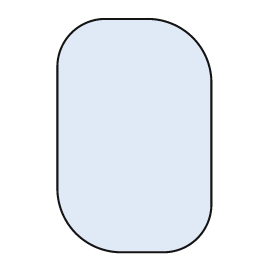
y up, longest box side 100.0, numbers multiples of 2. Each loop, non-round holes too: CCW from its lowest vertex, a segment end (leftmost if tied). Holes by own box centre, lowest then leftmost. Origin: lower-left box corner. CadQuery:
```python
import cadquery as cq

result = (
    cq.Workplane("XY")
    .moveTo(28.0, 0.0)
    .lineTo(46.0, 0.0)
    .threePointArc((60.0, 6.0), (66.0, 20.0))
    .lineTo(66.0, 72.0)
    .threePointArc((58.0, 92.0), (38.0, 100.0))
    .lineTo(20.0, 100.0)
    .threePointArc((6.0, 94.0), (0.0, 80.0))
    .lineTo(0.0, 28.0)
    .threePointArc((8.0, 8.0), (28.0, 0.0))
    .close()
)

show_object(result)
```